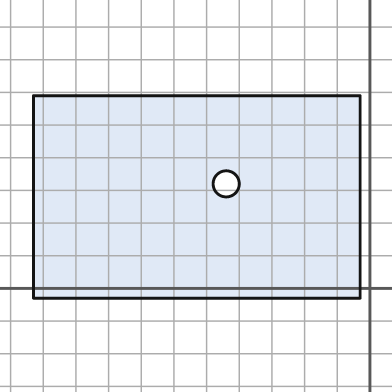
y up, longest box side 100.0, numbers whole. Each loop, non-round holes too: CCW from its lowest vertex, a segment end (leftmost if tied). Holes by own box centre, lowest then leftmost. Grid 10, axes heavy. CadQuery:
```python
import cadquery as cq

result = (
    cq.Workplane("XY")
    .moveTo(-103.0, -3.0)
    .lineTo(-3.0, -3.0)
    .lineTo(-3.0, 59.0)
    .lineTo(-103.0, 59.0)
    .close()
    .moveTo(-44.0, 32.0)
    .circle(4.0)
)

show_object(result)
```